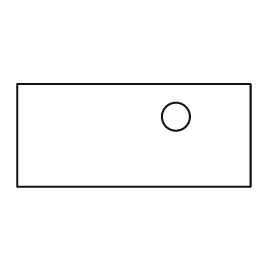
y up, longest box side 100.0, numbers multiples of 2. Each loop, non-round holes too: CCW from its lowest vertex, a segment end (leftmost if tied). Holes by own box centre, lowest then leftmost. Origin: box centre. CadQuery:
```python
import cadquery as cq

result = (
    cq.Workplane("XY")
    .moveTo(-50.0, -22.0)
    .lineTo(50.0, -22.0)
    .lineTo(50.0, 22.0)
    .lineTo(-50.0, 22.0)
    .close()
    .moveTo(18.0, 8.0)
    .circle(6.0)
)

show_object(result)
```